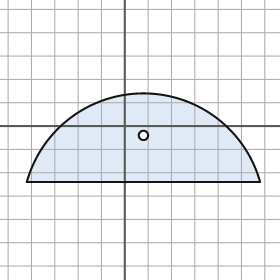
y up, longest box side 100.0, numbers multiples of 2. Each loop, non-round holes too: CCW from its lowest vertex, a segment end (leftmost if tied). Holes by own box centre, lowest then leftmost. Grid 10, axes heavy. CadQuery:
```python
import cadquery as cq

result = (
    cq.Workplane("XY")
    .moveTo(-42.0, -24.0)
    .lineTo(58.0, -24.0)
    .threePointArc((8.0, 14.0), (-42.0, -24.0))
    .close()
    .moveTo(8.0, -4.0)
    .circle(2.0)
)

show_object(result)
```